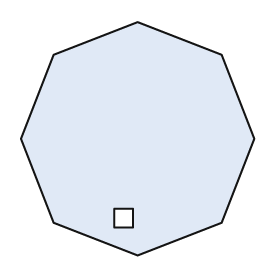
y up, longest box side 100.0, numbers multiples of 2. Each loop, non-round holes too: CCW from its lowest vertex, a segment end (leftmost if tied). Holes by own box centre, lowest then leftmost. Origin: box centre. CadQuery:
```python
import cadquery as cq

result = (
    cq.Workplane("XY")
    .moveTo(0.0, -50.0)
    .lineTo(36.0, -36.0)
    .lineTo(50.0, 0.0)
    .lineTo(36.0, 36.0)
    .lineTo(0.0, 50.0)
    .lineTo(-36.0, 36.0)
    .lineTo(-50.0, 0.0)
    .lineTo(-36.0, -36.0)
    .close()
    .moveTo(-10.0, -38.0)
    .lineTo(-2.0, -38.0)
    .lineTo(-2.0, -30.0)
    .lineTo(-10.0, -30.0)
    .close()
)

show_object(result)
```